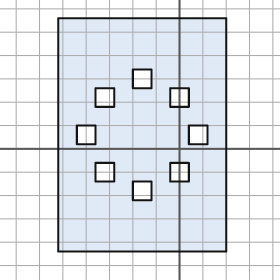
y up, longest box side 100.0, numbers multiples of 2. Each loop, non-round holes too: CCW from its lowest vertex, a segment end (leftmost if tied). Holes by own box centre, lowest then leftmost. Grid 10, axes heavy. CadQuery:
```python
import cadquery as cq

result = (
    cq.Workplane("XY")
    .moveTo(-52.0, -44.0)
    .lineTo(20.0, -44.0)
    .lineTo(20.0, 56.0)
    .lineTo(-52.0, 56.0)
    .close()
    .moveTo(-20.0, -22.0)
    .lineTo(-12.0, -22.0)
    .lineTo(-12.0, -14.0)
    .lineTo(-20.0, -14.0)
    .close()
    .moveTo(-36.0, -14.0)
    .lineTo(-28.0, -14.0)
    .lineTo(-28.0, -6.0)
    .lineTo(-36.0, -6.0)
    .close()
    .moveTo(-4.0, -14.0)
    .lineTo(4.0, -14.0)
    .lineTo(4.0, -6.0)
    .lineTo(-4.0, -6.0)
    .close()
    .moveTo(-44.0, 2.0)
    .lineTo(-36.0, 2.0)
    .lineTo(-36.0, 10.0)
    .lineTo(-44.0, 10.0)
    .close()
    .moveTo(4.0, 2.0)
    .lineTo(12.0, 2.0)
    .lineTo(12.0, 10.0)
    .lineTo(4.0, 10.0)
    .close()
    .moveTo(-36.0, 18.0)
    .lineTo(-28.0, 18.0)
    .lineTo(-28.0, 26.0)
    .lineTo(-36.0, 26.0)
    .close()
    .moveTo(-4.0, 18.0)
    .lineTo(4.0, 18.0)
    .lineTo(4.0, 26.0)
    .lineTo(-4.0, 26.0)
    .close()
    .moveTo(-20.0, 26.0)
    .lineTo(-12.0, 26.0)
    .lineTo(-12.0, 34.0)
    .lineTo(-20.0, 34.0)
    .close()
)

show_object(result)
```